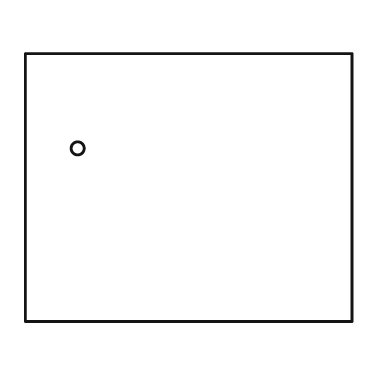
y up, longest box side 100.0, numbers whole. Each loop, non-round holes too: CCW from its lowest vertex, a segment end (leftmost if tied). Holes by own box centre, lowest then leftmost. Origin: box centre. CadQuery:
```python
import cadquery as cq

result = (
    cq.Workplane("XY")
    .moveTo(-50.0, -41.0)
    .lineTo(50.0, -41.0)
    .lineTo(50.0, 41.0)
    .lineTo(-50.0, 41.0)
    .close()
    .moveTo(-34.0, 12.0)
    .circle(2.0)
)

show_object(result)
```